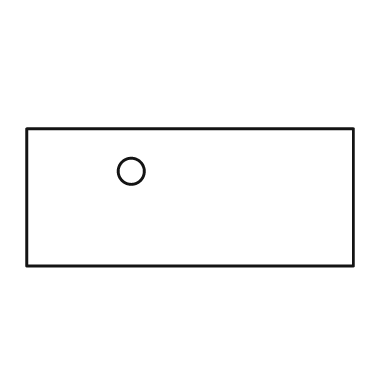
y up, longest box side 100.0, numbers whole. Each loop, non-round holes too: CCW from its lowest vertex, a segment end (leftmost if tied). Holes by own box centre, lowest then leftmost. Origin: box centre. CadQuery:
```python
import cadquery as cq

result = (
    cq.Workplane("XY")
    .moveTo(-50.0, -21.0)
    .lineTo(50.0, -21.0)
    .lineTo(50.0, 21.0)
    .lineTo(-50.0, 21.0)
    .close()
    .moveTo(-18.0, 8.0)
    .circle(4.0)
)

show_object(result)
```